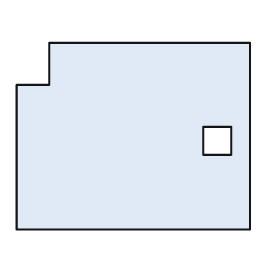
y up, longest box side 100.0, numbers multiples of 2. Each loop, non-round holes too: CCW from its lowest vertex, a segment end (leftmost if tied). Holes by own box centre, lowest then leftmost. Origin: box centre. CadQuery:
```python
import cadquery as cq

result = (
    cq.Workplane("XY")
    .moveTo(-50.0, -40.0)
    .lineTo(50.0, -40.0)
    .lineTo(50.0, 40.0)
    .lineTo(-36.0, 40.0)
    .lineTo(-36.0, 22.0)
    .lineTo(-50.0, 22.0)
    .close()
    .moveTo(30.0, -8.0)
    .lineTo(42.0, -8.0)
    .lineTo(42.0, 4.0)
    .lineTo(30.0, 4.0)
    .close()
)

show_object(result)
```